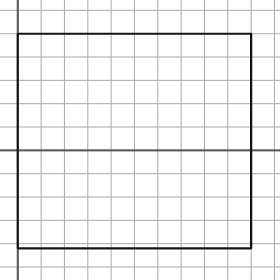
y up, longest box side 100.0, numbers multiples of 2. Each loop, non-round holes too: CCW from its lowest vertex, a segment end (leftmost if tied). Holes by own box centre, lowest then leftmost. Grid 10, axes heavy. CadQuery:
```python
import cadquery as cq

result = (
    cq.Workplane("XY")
    .moveTo(0.0, -42.0)
    .lineTo(100.0, -42.0)
    .lineTo(100.0, 50.0)
    .lineTo(0.0, 50.0)
    .close()
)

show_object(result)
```